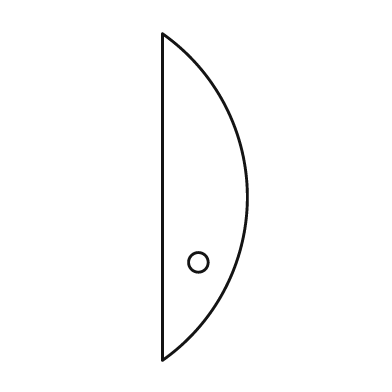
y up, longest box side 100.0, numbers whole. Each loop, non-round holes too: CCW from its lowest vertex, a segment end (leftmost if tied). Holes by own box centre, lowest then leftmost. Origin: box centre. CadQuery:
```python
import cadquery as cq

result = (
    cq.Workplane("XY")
    .moveTo(-13.0, -50.0)
    .threePointArc((13.0, 0.0), (-13.0, 50.0))
    .close()
    .moveTo(-2.0, -20.0)
    .circle(3.0)
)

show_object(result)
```